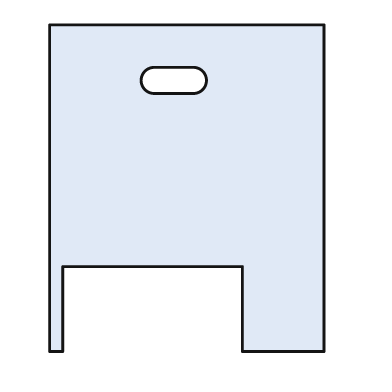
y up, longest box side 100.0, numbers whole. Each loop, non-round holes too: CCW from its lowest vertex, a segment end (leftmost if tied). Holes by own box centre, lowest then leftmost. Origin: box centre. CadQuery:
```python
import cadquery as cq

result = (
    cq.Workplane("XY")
    .moveTo(-42.0, -50.0)
    .lineTo(-38.0, -50.0)
    .lineTo(-38.0, -24.0)
    .lineTo(17.0, -24.0)
    .lineTo(17.0, -50.0)
    .lineTo(42.0, -50.0)
    .lineTo(42.0, 50.0)
    .lineTo(-42.0, 50.0)
    .close()
    .moveTo(-10.0, 29.0)
    .lineTo(2.0, 29.0)
    .threePointArc((6.0, 33.0), (2.0, 37.0))
    .lineTo(-10.0, 37.0)
    .threePointArc((-14.0, 33.0), (-10.0, 29.0))
    .close()
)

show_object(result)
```